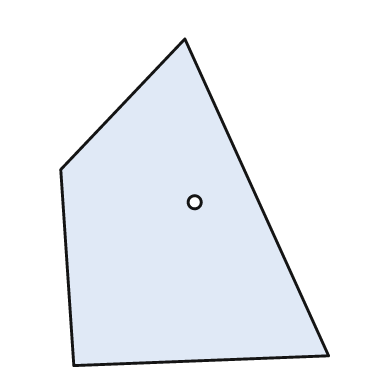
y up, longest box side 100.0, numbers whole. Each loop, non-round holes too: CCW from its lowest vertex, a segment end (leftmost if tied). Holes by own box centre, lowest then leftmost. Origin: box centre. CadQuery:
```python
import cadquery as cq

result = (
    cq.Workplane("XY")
    .moveTo(-37.0, -50.0)
    .lineTo(41.0, -47.0)
    .lineTo(-3.0, 50.0)
    .lineTo(-41.0, 10.0)
    .close()
    .moveTo(0.0, 0.0)
    .circle(2.0)
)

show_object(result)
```